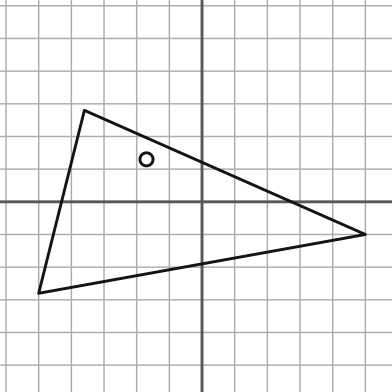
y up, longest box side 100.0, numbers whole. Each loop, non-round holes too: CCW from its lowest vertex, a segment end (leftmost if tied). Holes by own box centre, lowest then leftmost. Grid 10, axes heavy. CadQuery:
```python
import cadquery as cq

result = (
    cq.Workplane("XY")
    .moveTo(-50.0, -28.0)
    .lineTo(50.0, -10.0)
    .lineTo(-36.0, 28.0)
    .close()
    .moveTo(-17.0, 13.0)
    .circle(2.0)
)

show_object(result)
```